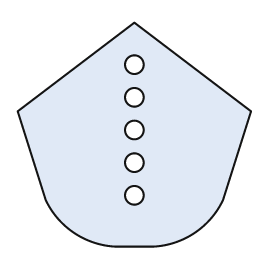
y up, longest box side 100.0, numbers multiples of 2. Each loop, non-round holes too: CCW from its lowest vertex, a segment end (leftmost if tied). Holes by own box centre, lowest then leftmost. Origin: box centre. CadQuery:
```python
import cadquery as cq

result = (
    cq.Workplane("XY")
    .moveTo(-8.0, -48.0)
    .lineTo(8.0, -48.0)
    .threePointArc((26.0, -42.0), (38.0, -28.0))
    .lineTo(50.0, 10.0)
    .lineTo(0.0, 48.0)
    .lineTo(-50.0, 10.0)
    .lineTo(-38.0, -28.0)
    .threePointArc((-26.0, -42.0), (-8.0, -48.0))
    .close()
    .moveTo(0.0, -26.0)
    .circle(4.0)
    .moveTo(0.0, -12.0)
    .circle(4.0)
    .moveTo(0.0, 2.0)
    .circle(4.0)
    .moveTo(0.0, 16.0)
    .circle(4.0)
    .moveTo(0.0, 30.0)
    .circle(4.0)
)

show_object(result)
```